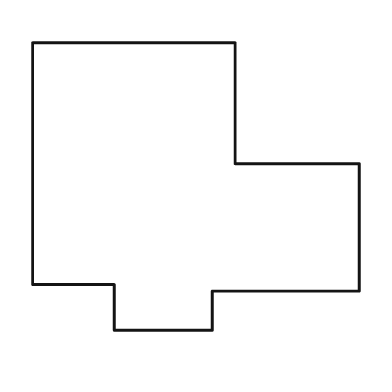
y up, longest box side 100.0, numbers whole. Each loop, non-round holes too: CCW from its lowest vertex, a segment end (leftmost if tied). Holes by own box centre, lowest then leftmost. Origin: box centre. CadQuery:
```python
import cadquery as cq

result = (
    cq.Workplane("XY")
    .moveTo(-25.0, -44.0)
    .lineTo(5.0, -44.0)
    .lineTo(5.0, -32.0)
    .lineTo(50.0, -32.0)
    .lineTo(50.0, 7.0)
    .lineTo(12.0, 7.0)
    .lineTo(12.0, 44.0)
    .lineTo(-50.0, 44.0)
    .lineTo(-50.0, -30.0)
    .lineTo(-25.0, -30.0)
    .close()
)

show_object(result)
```